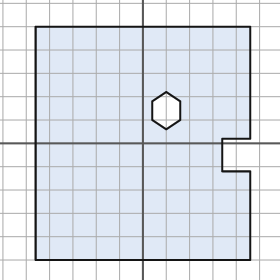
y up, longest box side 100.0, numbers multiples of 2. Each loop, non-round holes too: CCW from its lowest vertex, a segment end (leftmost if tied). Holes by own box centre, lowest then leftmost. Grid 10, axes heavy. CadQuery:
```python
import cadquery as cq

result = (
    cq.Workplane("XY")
    .moveTo(-46.0, -50.0)
    .lineTo(46.0, -50.0)
    .lineTo(46.0, -12.0)
    .lineTo(34.0, -12.0)
    .lineTo(34.0, 2.0)
    .lineTo(46.0, 2.0)
    .lineTo(46.0, 50.0)
    .lineTo(-46.0, 50.0)
    .close()
    .moveTo(10.0, 6.0)
    .lineTo(16.0, 10.0)
    .lineTo(16.0, 18.0)
    .lineTo(10.0, 22.0)
    .lineTo(4.0, 18.0)
    .lineTo(4.0, 10.0)
    .close()
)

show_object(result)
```